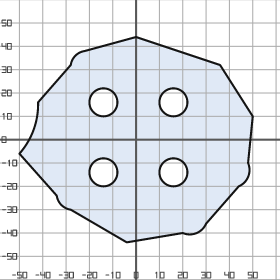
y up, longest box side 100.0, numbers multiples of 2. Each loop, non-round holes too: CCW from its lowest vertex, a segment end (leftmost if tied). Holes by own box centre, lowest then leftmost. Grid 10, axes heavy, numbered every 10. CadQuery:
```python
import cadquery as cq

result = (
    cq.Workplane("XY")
    .moveTo(-4.0, -44.0)
    .lineTo(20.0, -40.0)
    .threePointArc((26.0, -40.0), (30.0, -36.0))
    .lineTo(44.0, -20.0)
    .threePointArc((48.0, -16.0), (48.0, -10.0))
    .lineTo(50.0, 10.0)
    .lineTo(36.0, 32.0)
    .lineTo(0.0, 44.0)
    .lineTo(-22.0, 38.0)
    .threePointArc((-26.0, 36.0), (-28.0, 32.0))
    .lineTo(-42.0, 16.0)
    .threePointArc((-44.0, 4.0), (-50.0, -6.0))
    .lineTo(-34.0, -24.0)
    .threePointArc((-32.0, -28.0), (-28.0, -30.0))
    .close()
    .moveTo(-14.0, -14.0)
    .circle(6.0)
    .moveTo(16.0, -14.0)
    .circle(6.0)
    .moveTo(-14.0, 16.0)
    .circle(6.0)
    .moveTo(16.0, 16.0)
    .circle(6.0)
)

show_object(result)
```